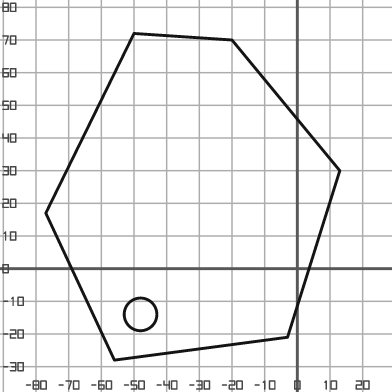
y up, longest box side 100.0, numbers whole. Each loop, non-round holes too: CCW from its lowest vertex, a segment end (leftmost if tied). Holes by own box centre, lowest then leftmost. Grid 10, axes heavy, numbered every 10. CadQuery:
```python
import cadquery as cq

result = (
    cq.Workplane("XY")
    .moveTo(-56.0, -28.0)
    .lineTo(-3.0, -21.0)
    .lineTo(13.0, 30.0)
    .lineTo(-20.0, 70.0)
    .lineTo(-50.0, 72.0)
    .lineTo(-77.0, 17.0)
    .close()
    .moveTo(-48.0, -14.0)
    .circle(5.0)
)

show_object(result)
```